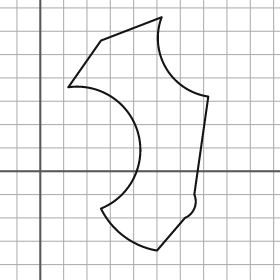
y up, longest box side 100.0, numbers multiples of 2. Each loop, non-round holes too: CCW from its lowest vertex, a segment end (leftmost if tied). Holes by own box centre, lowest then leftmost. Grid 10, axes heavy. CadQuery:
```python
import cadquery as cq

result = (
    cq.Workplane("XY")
    .moveTo(50.0, -34.0)
    .lineTo(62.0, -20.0)
    .threePointArc((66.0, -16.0), (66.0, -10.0))
    .lineTo(72.0, 32.0)
    .threePointArc((54.0, 44.0), (52.0, 66.0))
    .lineTo(26.0, 56.0)
    .lineTo(12.0, 36.0)
    .threePointArc((42.0, 16.0), (26.0, -16.0))
    .threePointArc((36.0, -28.0), (50.0, -34.0))
    .close()
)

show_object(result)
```